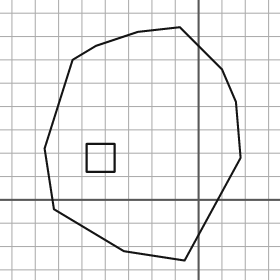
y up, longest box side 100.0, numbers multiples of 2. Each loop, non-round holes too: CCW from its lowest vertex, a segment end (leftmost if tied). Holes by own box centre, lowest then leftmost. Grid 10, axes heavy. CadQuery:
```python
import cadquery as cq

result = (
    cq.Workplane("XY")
    .moveTo(-6.0, -26.0)
    .lineTo(18.0, 18.0)
    .lineTo(16.0, 42.0)
    .lineTo(10.0, 56.0)
    .lineTo(-8.0, 74.0)
    .lineTo(-26.0, 72.0)
    .lineTo(-44.0, 66.0)
    .lineTo(-54.0, 60.0)
    .lineTo(-66.0, 22.0)
    .lineTo(-62.0, -4.0)
    .lineTo(-32.0, -22.0)
    .close()
    .moveTo(-48.0, 12.0)
    .lineTo(-36.0, 12.0)
    .lineTo(-36.0, 24.0)
    .lineTo(-48.0, 24.0)
    .close()
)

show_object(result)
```